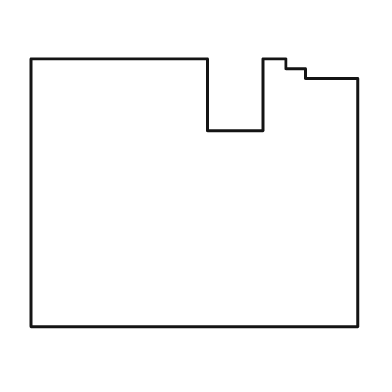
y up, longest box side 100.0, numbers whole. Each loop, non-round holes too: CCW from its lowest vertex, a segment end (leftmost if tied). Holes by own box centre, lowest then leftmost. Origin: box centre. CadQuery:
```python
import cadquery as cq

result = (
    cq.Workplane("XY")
    .moveTo(-50.0, -41.0)
    .lineTo(50.0, -41.0)
    .lineTo(50.0, 35.0)
    .lineTo(34.0, 35.0)
    .lineTo(34.0, 38.0)
    .lineTo(28.0, 38.0)
    .lineTo(28.0, 41.0)
    .lineTo(21.0, 41.0)
    .lineTo(21.0, 19.0)
    .lineTo(4.0, 19.0)
    .lineTo(4.0, 41.0)
    .lineTo(-50.0, 41.0)
    .close()
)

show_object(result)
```